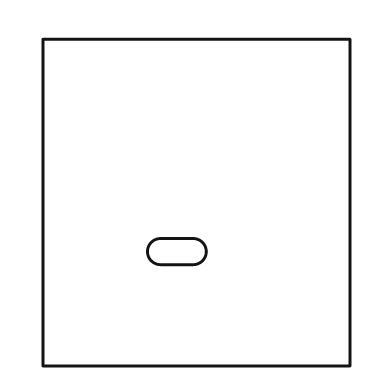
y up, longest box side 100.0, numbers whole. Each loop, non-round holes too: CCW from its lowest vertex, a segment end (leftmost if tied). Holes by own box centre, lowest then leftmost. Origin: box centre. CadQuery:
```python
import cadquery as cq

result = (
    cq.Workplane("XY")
    .moveTo(-47.0, -50.0)
    .lineTo(47.0, -50.0)
    .lineTo(47.0, 50.0)
    .lineTo(-47.0, 50.0)
    .close()
    .moveTo(-11.0, -19.0)
    .lineTo(-1.0, -19.0)
    .threePointArc((3.0, -15.0), (-1.0, -11.0))
    .lineTo(-11.0, -11.0)
    .threePointArc((-15.0, -15.0), (-11.0, -19.0))
    .close()
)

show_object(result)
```